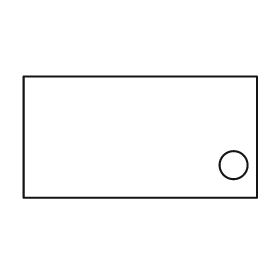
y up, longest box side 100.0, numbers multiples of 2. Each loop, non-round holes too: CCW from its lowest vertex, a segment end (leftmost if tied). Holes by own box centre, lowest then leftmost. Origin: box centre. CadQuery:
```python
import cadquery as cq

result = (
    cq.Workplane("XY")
    .moveTo(-50.0, -26.0)
    .lineTo(50.0, -26.0)
    .lineTo(50.0, 26.0)
    .lineTo(-50.0, 26.0)
    .close()
    .moveTo(40.0, -12.0)
    .circle(6.0)
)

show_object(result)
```